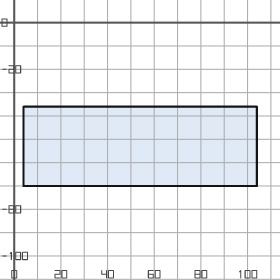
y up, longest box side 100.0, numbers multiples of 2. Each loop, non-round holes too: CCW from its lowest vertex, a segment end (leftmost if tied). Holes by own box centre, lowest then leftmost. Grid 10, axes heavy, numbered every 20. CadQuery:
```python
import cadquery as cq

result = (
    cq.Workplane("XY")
    .moveTo(4.0, -70.0)
    .lineTo(104.0, -70.0)
    .lineTo(104.0, -36.0)
    .lineTo(4.0, -36.0)
    .close()
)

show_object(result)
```